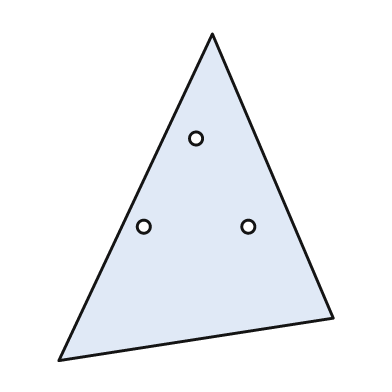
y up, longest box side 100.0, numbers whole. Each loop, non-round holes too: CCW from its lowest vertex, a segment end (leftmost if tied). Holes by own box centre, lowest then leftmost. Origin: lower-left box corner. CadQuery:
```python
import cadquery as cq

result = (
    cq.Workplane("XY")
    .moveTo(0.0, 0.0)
    .lineTo(84.0, 13.0)
    .lineTo(47.0, 100.0)
    .close()
    .moveTo(26.0, 41.0)
    .circle(2.0)
    .moveTo(58.0, 41.0)
    .circle(2.0)
    .moveTo(42.0, 68.0)
    .circle(2.0)
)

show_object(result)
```